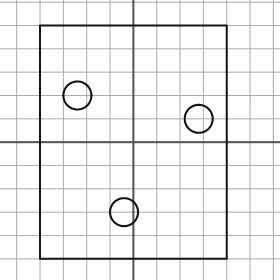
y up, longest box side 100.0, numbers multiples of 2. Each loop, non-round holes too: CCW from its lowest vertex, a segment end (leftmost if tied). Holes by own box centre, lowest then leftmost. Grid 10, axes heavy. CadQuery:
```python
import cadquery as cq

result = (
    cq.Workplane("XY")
    .moveTo(-40.0, -50.0)
    .lineTo(40.0, -50.0)
    .lineTo(40.0, 50.0)
    .lineTo(-40.0, 50.0)
    .close()
    .moveTo(-4.0, -30.0)
    .circle(6.0)
    .moveTo(28.0, 10.0)
    .circle(6.0)
    .moveTo(-24.0, 20.0)
    .circle(6.0)
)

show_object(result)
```